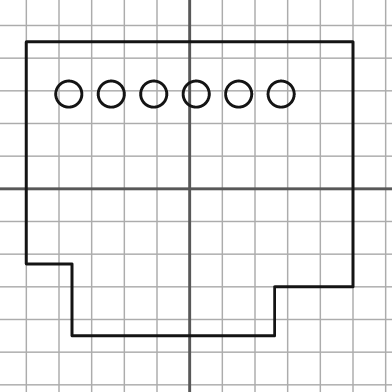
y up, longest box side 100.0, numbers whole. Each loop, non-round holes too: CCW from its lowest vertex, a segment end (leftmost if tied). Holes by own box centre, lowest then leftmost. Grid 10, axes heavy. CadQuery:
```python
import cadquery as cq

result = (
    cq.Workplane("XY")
    .moveTo(-36.0, -45.0)
    .lineTo(26.0, -45.0)
    .lineTo(26.0, -30.0)
    .lineTo(50.0, -30.0)
    .lineTo(50.0, 45.0)
    .lineTo(-50.0, 45.0)
    .lineTo(-50.0, -23.0)
    .lineTo(-36.0, -23.0)
    .close()
    .moveTo(-37.0, 29.0)
    .circle(4.0)
    .moveTo(-24.0, 29.0)
    .circle(4.0)
    .moveTo(-11.0, 29.0)
    .circle(4.0)
    .moveTo(2.0, 29.0)
    .circle(4.0)
    .moveTo(15.0, 29.0)
    .circle(4.0)
    .moveTo(28.0, 29.0)
    .circle(4.0)
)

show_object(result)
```